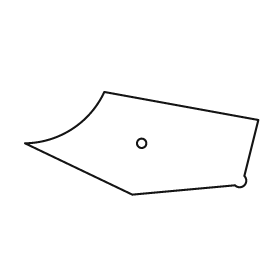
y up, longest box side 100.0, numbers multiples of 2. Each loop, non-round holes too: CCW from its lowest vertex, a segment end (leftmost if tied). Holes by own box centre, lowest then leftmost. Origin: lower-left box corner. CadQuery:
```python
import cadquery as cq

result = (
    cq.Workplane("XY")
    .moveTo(46.0, 0.0)
    .lineTo(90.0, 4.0)
    .threePointArc((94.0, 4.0), (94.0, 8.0))
    .lineTo(100.0, 32.0)
    .lineTo(34.0, 44.0)
    .threePointArc((20.0, 28.0), (0.0, 22.0))
    .close()
    .moveTo(50.0, 22.0)
    .circle(2.0)
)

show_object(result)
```